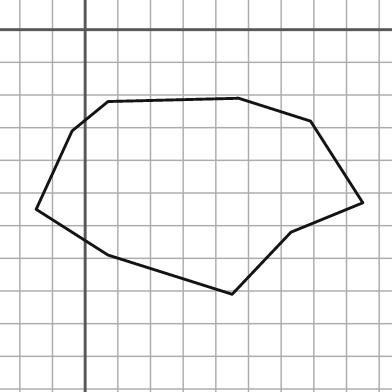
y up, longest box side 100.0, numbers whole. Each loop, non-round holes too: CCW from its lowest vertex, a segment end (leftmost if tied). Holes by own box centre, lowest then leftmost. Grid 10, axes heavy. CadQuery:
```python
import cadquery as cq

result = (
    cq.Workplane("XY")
    .moveTo(45.0, -81.0)
    .lineTo(63.0, -62.0)
    .lineTo(85.0, -53.0)
    .lineTo(69.0, -28.0)
    .lineTo(47.0, -21.0)
    .lineTo(7.0, -22.0)
    .lineTo(-4.0, -31.0)
    .lineTo(-15.0, -55.0)
    .lineTo(7.0, -69.0)
    .close()
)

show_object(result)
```